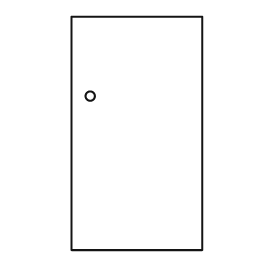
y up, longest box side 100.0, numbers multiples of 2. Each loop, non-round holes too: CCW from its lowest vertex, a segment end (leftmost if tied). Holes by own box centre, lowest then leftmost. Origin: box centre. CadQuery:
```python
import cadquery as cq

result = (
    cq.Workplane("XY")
    .moveTo(-28.0, -50.0)
    .lineTo(28.0, -50.0)
    .lineTo(28.0, 50.0)
    .lineTo(-28.0, 50.0)
    .close()
    .moveTo(-20.0, 16.0)
    .circle(2.0)
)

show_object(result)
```